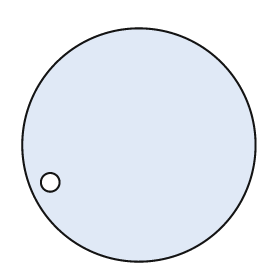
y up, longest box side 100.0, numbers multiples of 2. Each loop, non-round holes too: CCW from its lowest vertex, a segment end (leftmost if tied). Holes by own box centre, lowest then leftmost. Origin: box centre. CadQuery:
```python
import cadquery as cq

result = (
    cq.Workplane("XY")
    .moveTo(0.0, 0.0)
    .circle(50.0)
    .moveTo(-38.0, -16.0)
    .circle(4.0)
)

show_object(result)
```